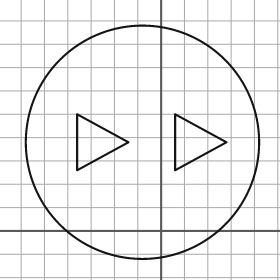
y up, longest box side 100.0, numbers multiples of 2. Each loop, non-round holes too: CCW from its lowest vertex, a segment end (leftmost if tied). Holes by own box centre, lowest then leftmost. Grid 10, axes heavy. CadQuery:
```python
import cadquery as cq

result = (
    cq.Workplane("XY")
    .moveTo(-8.0, 38.0)
    .circle(50.0)
    .moveTo(-36.0, 26.0)
    .lineTo(-14.0, 38.0)
    .lineTo(-36.0, 50.0)
    .close()
    .moveTo(6.0, 26.0)
    .lineTo(28.0, 38.0)
    .lineTo(6.0, 50.0)
    .close()
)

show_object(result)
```